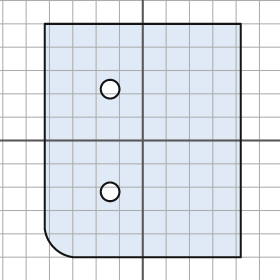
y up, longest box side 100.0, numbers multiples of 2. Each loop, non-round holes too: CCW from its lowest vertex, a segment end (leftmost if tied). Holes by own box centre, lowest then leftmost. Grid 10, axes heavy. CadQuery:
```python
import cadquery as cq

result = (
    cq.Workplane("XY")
    .moveTo(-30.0, -50.0)
    .lineTo(42.0, -50.0)
    .lineTo(42.0, 50.0)
    .lineTo(-42.0, 50.0)
    .lineTo(-42.0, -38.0)
    .threePointArc((-38.0, -46.0), (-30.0, -50.0))
    .close()
    .moveTo(-14.0, -22.0)
    .circle(4.0)
    .moveTo(-14.0, 22.0)
    .circle(4.0)
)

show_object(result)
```